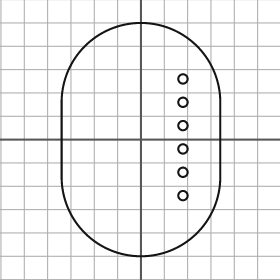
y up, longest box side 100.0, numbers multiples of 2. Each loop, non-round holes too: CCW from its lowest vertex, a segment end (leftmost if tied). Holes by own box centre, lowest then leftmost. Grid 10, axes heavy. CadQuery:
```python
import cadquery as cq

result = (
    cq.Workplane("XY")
    .moveTo(-34.0, -16.0)
    .threePointArc((0.0, -50.0), (34.0, -16.0))
    .lineTo(34.0, 16.0)
    .threePointArc((0.0, 50.0), (-34.0, 16.0))
    .close()
    .moveTo(18.0, -24.0)
    .circle(2.0)
    .moveTo(18.0, -14.0)
    .circle(2.0)
    .moveTo(18.0, -4.0)
    .circle(2.0)
    .moveTo(18.0, 6.0)
    .circle(2.0)
    .moveTo(18.0, 16.0)
    .circle(2.0)
    .moveTo(18.0, 26.0)
    .circle(2.0)
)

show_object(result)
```